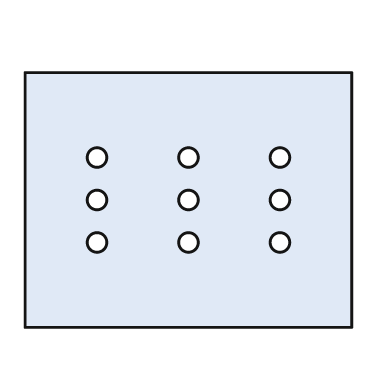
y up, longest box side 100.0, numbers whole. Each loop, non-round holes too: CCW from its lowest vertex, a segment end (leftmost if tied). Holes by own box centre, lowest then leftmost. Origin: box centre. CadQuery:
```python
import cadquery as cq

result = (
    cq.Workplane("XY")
    .moveTo(-50.0, -39.0)
    .lineTo(50.0, -39.0)
    .lineTo(50.0, 39.0)
    .lineTo(-50.0, 39.0)
    .close()
    .moveTo(-28.0, -13.0)
    .circle(3.0)
    .moveTo(0.0, -13.0)
    .circle(3.0)
    .moveTo(28.0, -13.0)
    .circle(3.0)
    .moveTo(-28.0, 0.0)
    .circle(3.0)
    .moveTo(0.0, 0.0)
    .circle(3.0)
    .moveTo(28.0, 0.0)
    .circle(3.0)
    .moveTo(-28.0, 13.0)
    .circle(3.0)
    .moveTo(0.0, 13.0)
    .circle(3.0)
    .moveTo(28.0, 13.0)
    .circle(3.0)
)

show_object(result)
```